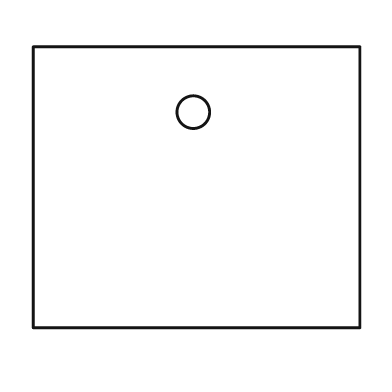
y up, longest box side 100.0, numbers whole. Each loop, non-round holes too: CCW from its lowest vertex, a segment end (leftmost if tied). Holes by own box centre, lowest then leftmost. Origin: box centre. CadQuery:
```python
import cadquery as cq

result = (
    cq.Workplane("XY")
    .moveTo(-50.0, -43.0)
    .lineTo(50.0, -43.0)
    .lineTo(50.0, 43.0)
    .lineTo(-50.0, 43.0)
    .close()
    .moveTo(-1.0, 23.0)
    .circle(5.0)
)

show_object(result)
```